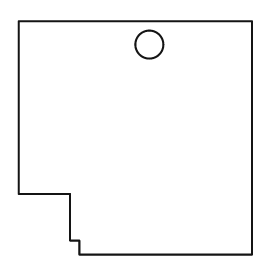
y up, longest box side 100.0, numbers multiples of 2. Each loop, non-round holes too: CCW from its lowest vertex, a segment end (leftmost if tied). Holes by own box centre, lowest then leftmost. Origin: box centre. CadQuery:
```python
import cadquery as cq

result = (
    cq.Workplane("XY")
    .moveTo(-24.0, -50.0)
    .lineTo(50.0, -50.0)
    .lineTo(50.0, 50.0)
    .lineTo(-50.0, 50.0)
    .lineTo(-50.0, -24.0)
    .lineTo(-28.0, -24.0)
    .lineTo(-28.0, -44.0)
    .lineTo(-24.0, -44.0)
    .close()
    .moveTo(6.0, 40.0)
    .circle(6.0)
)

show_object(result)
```